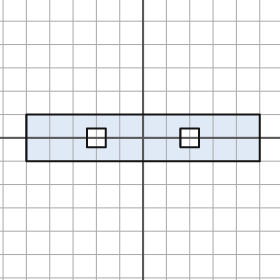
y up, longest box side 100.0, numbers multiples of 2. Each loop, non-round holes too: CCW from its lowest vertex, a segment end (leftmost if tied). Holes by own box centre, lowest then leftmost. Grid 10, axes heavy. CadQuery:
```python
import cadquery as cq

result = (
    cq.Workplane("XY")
    .moveTo(-50.0, -10.0)
    .lineTo(50.0, -10.0)
    .lineTo(50.0, 10.0)
    .lineTo(-50.0, 10.0)
    .close()
    .moveTo(-24.0, -4.0)
    .lineTo(-16.0, -4.0)
    .lineTo(-16.0, 4.0)
    .lineTo(-24.0, 4.0)
    .close()
    .moveTo(16.0, -4.0)
    .lineTo(24.0, -4.0)
    .lineTo(24.0, 4.0)
    .lineTo(16.0, 4.0)
    .close()
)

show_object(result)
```